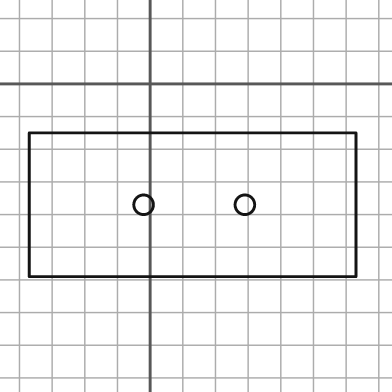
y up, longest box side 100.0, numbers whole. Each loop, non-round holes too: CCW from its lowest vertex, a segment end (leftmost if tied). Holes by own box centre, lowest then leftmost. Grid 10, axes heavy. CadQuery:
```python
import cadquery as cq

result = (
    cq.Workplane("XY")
    .moveTo(-37.0, -59.0)
    .lineTo(63.0, -59.0)
    .lineTo(63.0, -15.0)
    .lineTo(-37.0, -15.0)
    .close()
    .moveTo(-2.0, -37.0)
    .circle(3.0)
    .moveTo(29.0, -37.0)
    .circle(3.0)
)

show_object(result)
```